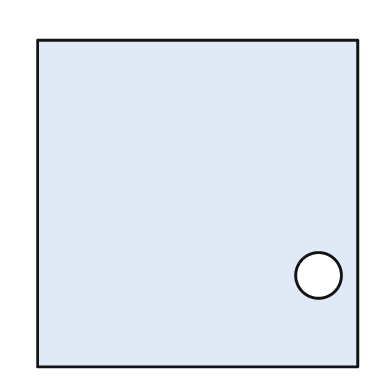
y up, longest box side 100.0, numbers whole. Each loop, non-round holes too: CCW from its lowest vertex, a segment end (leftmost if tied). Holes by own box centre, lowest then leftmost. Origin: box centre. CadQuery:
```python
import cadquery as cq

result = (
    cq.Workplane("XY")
    .moveTo(-49.0, -50.0)
    .lineTo(49.0, -50.0)
    .lineTo(49.0, 50.0)
    .lineTo(-49.0, 50.0)
    .close()
    .moveTo(37.0, -22.0)
    .circle(7.0)
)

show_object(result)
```